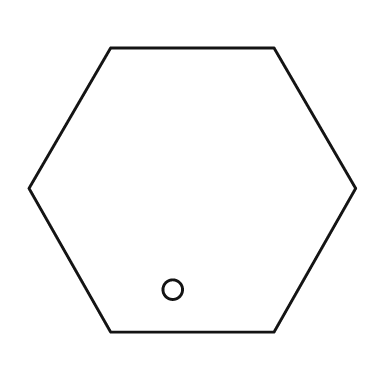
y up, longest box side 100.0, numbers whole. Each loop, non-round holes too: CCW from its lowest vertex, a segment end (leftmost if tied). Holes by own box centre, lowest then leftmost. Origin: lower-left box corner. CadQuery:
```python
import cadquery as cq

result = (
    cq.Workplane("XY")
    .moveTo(25.0, 0.0)
    .lineTo(75.0, 0.0)
    .lineTo(100.0, 44.0)
    .lineTo(75.0, 87.0)
    .lineTo(25.0, 87.0)
    .lineTo(0.0, 44.0)
    .close()
    .moveTo(44.0, 13.0)
    .circle(3.0)
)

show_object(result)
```